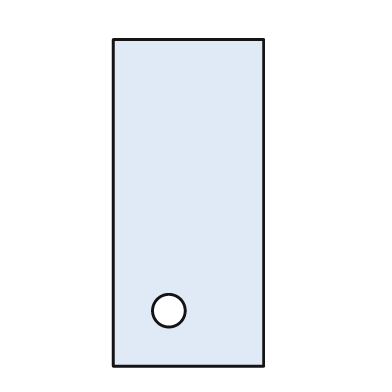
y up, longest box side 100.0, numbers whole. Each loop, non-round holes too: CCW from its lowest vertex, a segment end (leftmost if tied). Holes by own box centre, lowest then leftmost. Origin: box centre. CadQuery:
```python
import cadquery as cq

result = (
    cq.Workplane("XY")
    .moveTo(-23.0, -50.0)
    .lineTo(23.0, -50.0)
    .lineTo(23.0, 50.0)
    .lineTo(-23.0, 50.0)
    .close()
    .moveTo(-6.0, -33.0)
    .circle(5.0)
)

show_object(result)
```